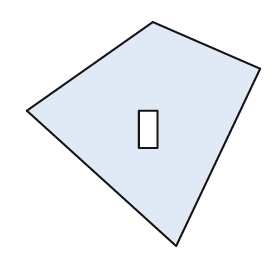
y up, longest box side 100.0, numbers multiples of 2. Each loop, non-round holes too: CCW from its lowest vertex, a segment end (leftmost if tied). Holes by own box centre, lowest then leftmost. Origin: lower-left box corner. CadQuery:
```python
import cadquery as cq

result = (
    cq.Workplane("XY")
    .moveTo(64.0, 0.0)
    .lineTo(100.0, 76.0)
    .lineTo(54.0, 96.0)
    .lineTo(0.0, 58.0)
    .close()
    .moveTo(48.0, 42.0)
    .lineTo(56.0, 42.0)
    .lineTo(56.0, 58.0)
    .lineTo(48.0, 58.0)
    .close()
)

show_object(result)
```